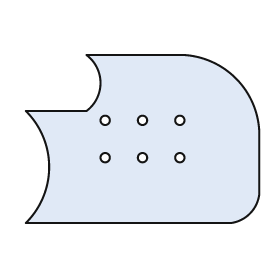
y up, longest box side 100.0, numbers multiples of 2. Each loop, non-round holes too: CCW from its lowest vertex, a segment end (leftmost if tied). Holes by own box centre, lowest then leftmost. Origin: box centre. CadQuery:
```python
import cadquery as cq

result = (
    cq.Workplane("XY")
    .moveTo(-50.0, -36.0)
    .lineTo(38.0, -36.0)
    .threePointArc((46.0, -32.0), (50.0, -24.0))
    .lineTo(50.0, 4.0)
    .threePointArc((40.0, 26.0), (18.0, 36.0))
    .lineTo(-24.0, 36.0)
    .threePointArc((-18.0, 24.0), (-24.0, 12.0))
    .lineTo(-50.0, 12.0)
    .threePointArc((-40.0, -12.0), (-50.0, -36.0))
    .close()
    .moveTo(-16.0, -8.0)
    .circle(2.0)
    .moveTo(0.0, -8.0)
    .circle(2.0)
    .moveTo(16.0, -8.0)
    .circle(2.0)
    .moveTo(-16.0, 8.0)
    .circle(2.0)
    .moveTo(0.0, 8.0)
    .circle(2.0)
    .moveTo(16.0, 8.0)
    .circle(2.0)
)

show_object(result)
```